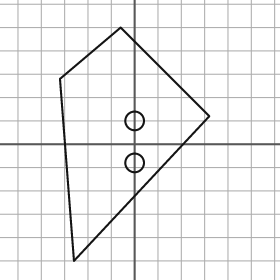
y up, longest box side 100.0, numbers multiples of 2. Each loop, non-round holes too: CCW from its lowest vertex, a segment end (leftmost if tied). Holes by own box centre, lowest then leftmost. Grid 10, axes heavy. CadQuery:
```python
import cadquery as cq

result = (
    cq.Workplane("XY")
    .moveTo(-26.0, -50.0)
    .lineTo(32.0, 12.0)
    .lineTo(-6.0, 50.0)
    .lineTo(-32.0, 28.0)
    .close()
    .moveTo(0.0, -8.0)
    .circle(4.0)
    .moveTo(0.0, 10.0)
    .circle(4.0)
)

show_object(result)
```